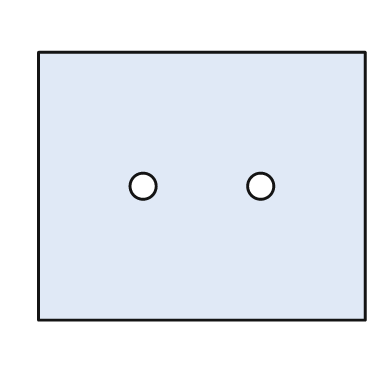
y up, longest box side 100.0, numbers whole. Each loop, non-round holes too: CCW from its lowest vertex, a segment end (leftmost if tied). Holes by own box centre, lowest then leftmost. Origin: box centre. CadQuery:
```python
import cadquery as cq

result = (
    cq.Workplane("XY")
    .moveTo(-50.0, -41.0)
    .lineTo(50.0, -41.0)
    .lineTo(50.0, 41.0)
    .lineTo(-50.0, 41.0)
    .close()
    .moveTo(-18.0, 0.0)
    .circle(4.0)
    .moveTo(18.0, 0.0)
    .circle(4.0)
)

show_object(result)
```